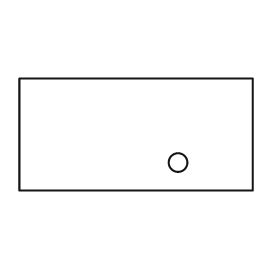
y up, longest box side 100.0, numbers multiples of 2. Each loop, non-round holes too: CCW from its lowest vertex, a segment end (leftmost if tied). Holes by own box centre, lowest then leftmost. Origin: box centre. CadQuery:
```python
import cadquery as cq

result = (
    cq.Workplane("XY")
    .moveTo(-50.0, -24.0)
    .lineTo(50.0, -24.0)
    .lineTo(50.0, 24.0)
    .lineTo(-50.0, 24.0)
    .close()
    .moveTo(18.0, -12.0)
    .circle(4.0)
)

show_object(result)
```